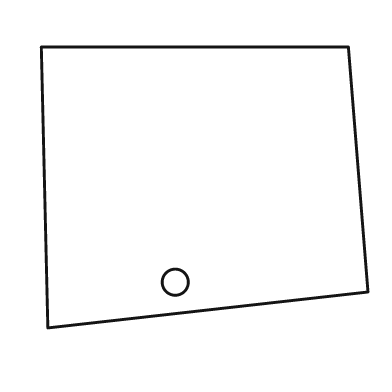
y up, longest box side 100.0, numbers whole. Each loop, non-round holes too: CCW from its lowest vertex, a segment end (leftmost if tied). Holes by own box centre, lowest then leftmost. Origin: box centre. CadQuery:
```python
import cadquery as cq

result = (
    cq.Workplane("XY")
    .moveTo(-48.0, -43.0)
    .lineTo(50.0, -32.0)
    .lineTo(44.0, 43.0)
    .lineTo(-50.0, 43.0)
    .close()
    .moveTo(-9.0, -29.0)
    .circle(4.0)
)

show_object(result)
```